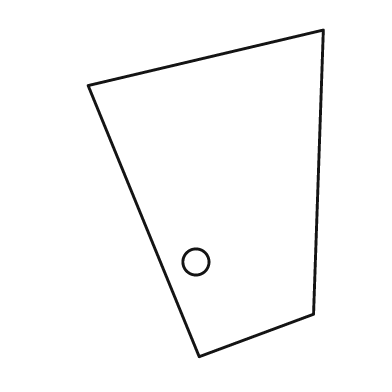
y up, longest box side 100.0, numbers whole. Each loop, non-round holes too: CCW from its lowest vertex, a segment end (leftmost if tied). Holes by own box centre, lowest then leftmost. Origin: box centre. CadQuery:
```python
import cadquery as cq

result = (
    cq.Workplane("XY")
    .moveTo(-2.0, -50.0)
    .lineTo(33.0, -37.0)
    .lineTo(36.0, 50.0)
    .lineTo(-36.0, 33.0)
    .close()
    .moveTo(-3.0, -21.0)
    .circle(4.0)
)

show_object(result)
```